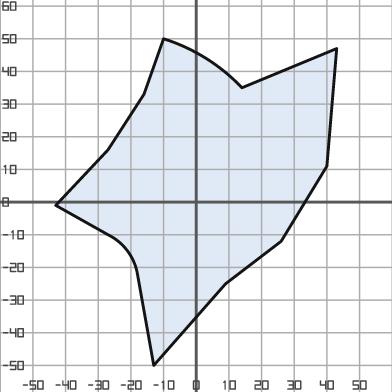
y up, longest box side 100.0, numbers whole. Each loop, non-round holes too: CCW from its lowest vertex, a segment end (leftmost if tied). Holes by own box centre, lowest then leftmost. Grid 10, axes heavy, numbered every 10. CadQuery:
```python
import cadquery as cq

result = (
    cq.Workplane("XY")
    .moveTo(-13.0, -50.0)
    .lineTo(9.0, -25.0)
    .lineTo(26.0, -12.0)
    .lineTo(40.0, 11.0)
    .lineTo(43.0, 47.0)
    .lineTo(14.0, 35.0)
    .threePointArc((3.0, 44.0), (-10.0, 50.0))
    .lineTo(-16.0, 33.0)
    .lineTo(-27.0, 16.0)
    .lineTo(-43.0, -1.0)
    .lineTo(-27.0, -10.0)
    .threePointArc((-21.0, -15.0), (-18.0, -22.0))
    .close()
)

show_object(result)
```